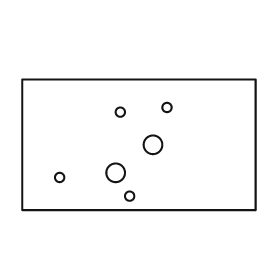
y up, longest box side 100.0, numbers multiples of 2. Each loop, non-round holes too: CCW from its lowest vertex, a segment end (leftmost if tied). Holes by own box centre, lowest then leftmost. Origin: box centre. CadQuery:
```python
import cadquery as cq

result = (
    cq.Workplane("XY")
    .moveTo(-50.0, -28.0)
    .lineTo(50.0, -28.0)
    .lineTo(50.0, 28.0)
    .lineTo(-50.0, 28.0)
    .close()
    .moveTo(-4.0, -22.0)
    .circle(2.0)
    .moveTo(-34.0, -14.0)
    .circle(2.0)
    .moveTo(-10.0, -12.0)
    .circle(4.0)
    .moveTo(6.0, 0.0)
    .circle(4.0)
    .moveTo(-8.0, 14.0)
    .circle(2.0)
    .moveTo(12.0, 16.0)
    .circle(2.0)
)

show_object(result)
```